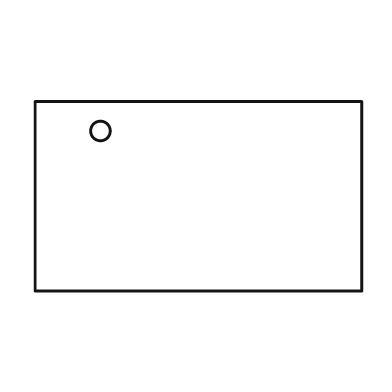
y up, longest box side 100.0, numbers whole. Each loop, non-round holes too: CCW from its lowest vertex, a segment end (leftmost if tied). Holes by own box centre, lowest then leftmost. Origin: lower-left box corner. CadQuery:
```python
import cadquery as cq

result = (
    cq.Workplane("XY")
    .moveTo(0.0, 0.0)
    .lineTo(100.0, 0.0)
    .lineTo(100.0, 58.0)
    .lineTo(0.0, 58.0)
    .close()
    .moveTo(20.0, 49.0)
    .circle(3.0)
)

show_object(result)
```